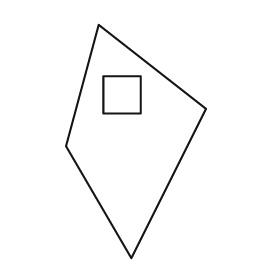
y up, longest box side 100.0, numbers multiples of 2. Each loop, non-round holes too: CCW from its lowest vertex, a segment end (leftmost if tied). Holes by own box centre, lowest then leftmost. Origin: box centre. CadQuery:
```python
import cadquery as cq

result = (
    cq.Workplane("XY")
    .moveTo(-2.0, -50.0)
    .lineTo(30.0, 14.0)
    .lineTo(-16.0, 50.0)
    .lineTo(-30.0, -2.0)
    .close()
    .moveTo(-14.0, 12.0)
    .lineTo(2.0, 12.0)
    .lineTo(2.0, 28.0)
    .lineTo(-14.0, 28.0)
    .close()
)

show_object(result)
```